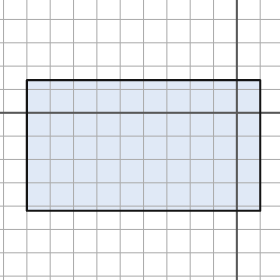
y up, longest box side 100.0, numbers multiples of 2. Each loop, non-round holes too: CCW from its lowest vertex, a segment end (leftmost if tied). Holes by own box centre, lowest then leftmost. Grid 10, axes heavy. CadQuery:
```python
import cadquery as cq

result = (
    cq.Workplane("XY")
    .moveTo(-90.0, -42.0)
    .lineTo(10.0, -42.0)
    .lineTo(10.0, 14.0)
    .lineTo(-90.0, 14.0)
    .close()
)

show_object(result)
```